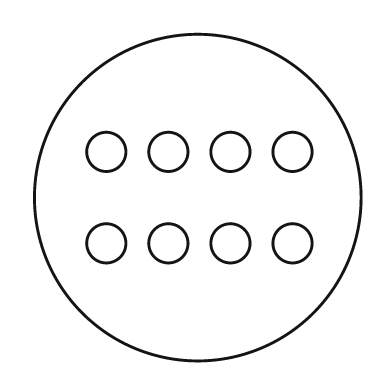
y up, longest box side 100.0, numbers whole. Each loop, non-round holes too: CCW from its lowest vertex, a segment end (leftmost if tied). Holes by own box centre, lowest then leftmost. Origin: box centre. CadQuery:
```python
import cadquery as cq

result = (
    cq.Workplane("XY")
    .moveTo(0.0, 0.0)
    .circle(50.0)
    .moveTo(-28.0, -14.0)
    .circle(6.0)
    .moveTo(-9.0, -14.0)
    .circle(6.0)
    .moveTo(10.0, -14.0)
    .circle(6.0)
    .moveTo(29.0, -14.0)
    .circle(6.0)
    .moveTo(-28.0, 14.0)
    .circle(6.0)
    .moveTo(-9.0, 14.0)
    .circle(6.0)
    .moveTo(10.0, 14.0)
    .circle(6.0)
    .moveTo(29.0, 14.0)
    .circle(6.0)
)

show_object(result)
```